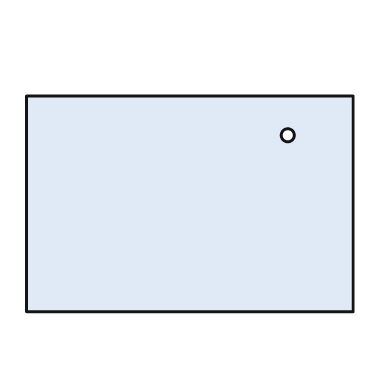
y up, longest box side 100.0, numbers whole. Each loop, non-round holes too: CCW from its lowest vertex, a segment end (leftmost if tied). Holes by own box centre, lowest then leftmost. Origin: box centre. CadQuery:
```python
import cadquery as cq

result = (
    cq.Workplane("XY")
    .moveTo(-50.0, -33.0)
    .lineTo(50.0, -33.0)
    .lineTo(50.0, 33.0)
    .lineTo(-50.0, 33.0)
    .close()
    .moveTo(30.0, 21.0)
    .circle(2.0)
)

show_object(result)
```